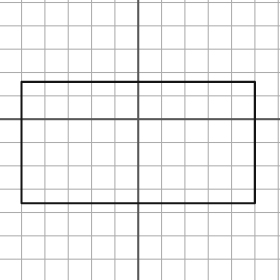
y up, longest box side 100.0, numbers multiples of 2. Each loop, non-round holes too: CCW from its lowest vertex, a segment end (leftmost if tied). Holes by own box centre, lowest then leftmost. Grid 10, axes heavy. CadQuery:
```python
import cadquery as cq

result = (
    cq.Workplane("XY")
    .moveTo(-50.0, -36.0)
    .lineTo(50.0, -36.0)
    .lineTo(50.0, 16.0)
    .lineTo(-50.0, 16.0)
    .close()
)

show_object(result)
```